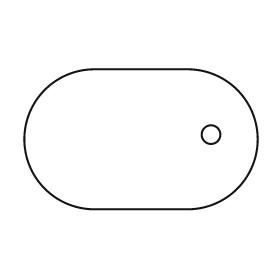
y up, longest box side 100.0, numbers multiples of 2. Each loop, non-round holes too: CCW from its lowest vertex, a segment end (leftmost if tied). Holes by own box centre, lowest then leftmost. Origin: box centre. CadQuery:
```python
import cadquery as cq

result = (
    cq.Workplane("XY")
    .moveTo(-20.0, -30.0)
    .lineTo(20.0, -30.0)
    .threePointArc((50.0, 0.0), (20.0, 30.0))
    .lineTo(-20.0, 30.0)
    .threePointArc((-50.0, 0.0), (-20.0, -30.0))
    .close()
    .moveTo(30.0, 2.0)
    .circle(4.0)
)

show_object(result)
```